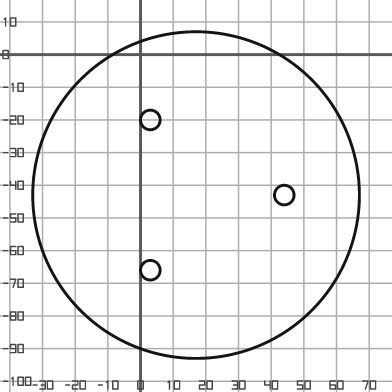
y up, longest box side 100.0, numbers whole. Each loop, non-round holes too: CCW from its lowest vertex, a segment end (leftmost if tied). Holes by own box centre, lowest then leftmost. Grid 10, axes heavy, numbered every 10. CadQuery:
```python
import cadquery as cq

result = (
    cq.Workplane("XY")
    .moveTo(17.0, -43.0)
    .circle(50.0)
    .moveTo(3.0, -66.0)
    .circle(3.0)
    .moveTo(44.0, -43.0)
    .circle(3.0)
    .moveTo(3.0, -20.0)
    .circle(3.0)
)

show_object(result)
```